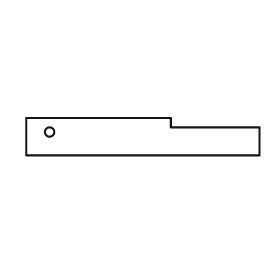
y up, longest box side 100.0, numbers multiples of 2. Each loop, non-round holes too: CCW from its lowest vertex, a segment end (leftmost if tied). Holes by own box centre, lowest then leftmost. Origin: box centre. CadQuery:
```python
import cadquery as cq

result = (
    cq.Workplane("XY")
    .moveTo(-50.0, -8.0)
    .lineTo(50.0, -8.0)
    .lineTo(50.0, 4.0)
    .lineTo(12.0, 4.0)
    .lineTo(12.0, 8.0)
    .lineTo(-50.0, 8.0)
    .close()
    .moveTo(-40.0, 2.0)
    .circle(2.0)
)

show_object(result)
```